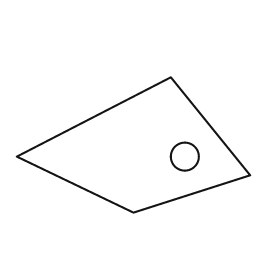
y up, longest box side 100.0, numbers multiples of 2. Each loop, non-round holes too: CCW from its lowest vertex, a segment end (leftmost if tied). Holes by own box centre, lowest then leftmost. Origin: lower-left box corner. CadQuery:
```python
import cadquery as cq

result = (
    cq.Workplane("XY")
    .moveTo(50.0, 0.0)
    .lineTo(100.0, 16.0)
    .lineTo(66.0, 58.0)
    .lineTo(0.0, 24.0)
    .close()
    .moveTo(72.0, 24.0)
    .circle(6.0)
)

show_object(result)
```